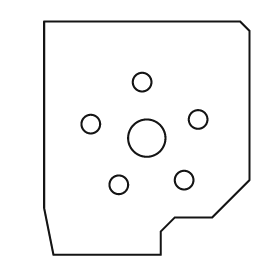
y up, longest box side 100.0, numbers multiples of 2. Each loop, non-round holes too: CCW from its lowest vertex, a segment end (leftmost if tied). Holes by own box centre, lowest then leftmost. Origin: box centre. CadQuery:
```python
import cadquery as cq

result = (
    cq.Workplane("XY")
    .moveTo(-40.0, -50.0)
    .lineTo(6.0, -50.0)
    .lineTo(6.0, -40.0)
    .lineTo(12.0, -34.0)
    .lineTo(28.0, -34.0)
    .lineTo(44.0, -18.0)
    .lineTo(44.0, 46.0)
    .lineTo(40.0, 50.0)
    .lineTo(-44.0, 50.0)
    .lineTo(-44.0, -30.0)
    .close()
    .moveTo(-12.0, -20.0)
    .circle(4.0)
    .moveTo(16.0, -18.0)
    .circle(4.0)
    .moveTo(0.0, 0.0)
    .circle(8.0)
    .moveTo(-24.0, 6.0)
    .circle(4.0)
    .moveTo(22.0, 8.0)
    .circle(4.0)
    .moveTo(-2.0, 24.0)
    .circle(4.0)
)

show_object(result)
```